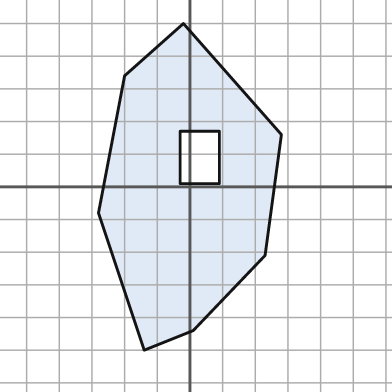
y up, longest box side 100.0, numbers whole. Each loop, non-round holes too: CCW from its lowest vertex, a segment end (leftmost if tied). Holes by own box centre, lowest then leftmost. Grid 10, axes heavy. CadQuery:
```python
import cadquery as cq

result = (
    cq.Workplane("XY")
    .moveTo(-14.0, -50.0)
    .lineTo(1.0, -44.0)
    .lineTo(23.0, -21.0)
    .lineTo(28.0, 16.0)
    .lineTo(-2.0, 50.0)
    .lineTo(-20.0, 34.0)
    .lineTo(-28.0, -8.0)
    .close()
    .moveTo(-3.0, 1.0)
    .lineTo(9.0, 1.0)
    .lineTo(9.0, 17.0)
    .lineTo(-3.0, 17.0)
    .close()
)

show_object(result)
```